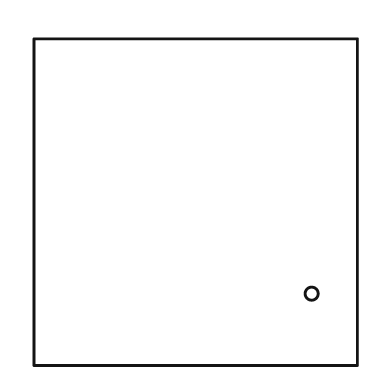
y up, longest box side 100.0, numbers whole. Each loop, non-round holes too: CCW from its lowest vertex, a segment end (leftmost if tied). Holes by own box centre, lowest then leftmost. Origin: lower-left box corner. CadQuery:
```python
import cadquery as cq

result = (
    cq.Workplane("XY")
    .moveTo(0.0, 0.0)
    .lineTo(99.0, 0.0)
    .lineTo(99.0, 100.0)
    .lineTo(0.0, 100.0)
    .close()
    .moveTo(85.0, 22.0)
    .circle(2.0)
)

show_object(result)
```